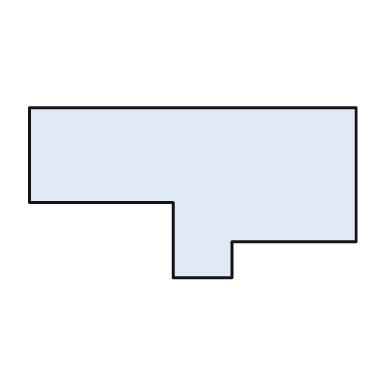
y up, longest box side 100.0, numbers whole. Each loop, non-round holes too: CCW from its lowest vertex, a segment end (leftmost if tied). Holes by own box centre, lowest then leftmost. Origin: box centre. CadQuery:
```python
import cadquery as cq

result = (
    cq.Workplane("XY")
    .moveTo(-6.0, -26.0)
    .lineTo(12.0, -26.0)
    .lineTo(12.0, -15.0)
    .lineTo(50.0, -15.0)
    .lineTo(50.0, 26.0)
    .lineTo(-50.0, 26.0)
    .lineTo(-50.0, -3.0)
    .lineTo(-6.0, -3.0)
    .close()
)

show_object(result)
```